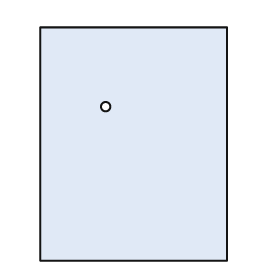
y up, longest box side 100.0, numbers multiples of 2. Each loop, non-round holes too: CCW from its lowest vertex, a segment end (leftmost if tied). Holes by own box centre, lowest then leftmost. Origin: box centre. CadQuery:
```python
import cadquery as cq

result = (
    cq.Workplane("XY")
    .moveTo(-40.0, -50.0)
    .lineTo(40.0, -50.0)
    .lineTo(40.0, 50.0)
    .lineTo(-40.0, 50.0)
    .close()
    .moveTo(-12.0, 16.0)
    .circle(2.0)
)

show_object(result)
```